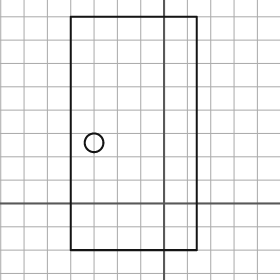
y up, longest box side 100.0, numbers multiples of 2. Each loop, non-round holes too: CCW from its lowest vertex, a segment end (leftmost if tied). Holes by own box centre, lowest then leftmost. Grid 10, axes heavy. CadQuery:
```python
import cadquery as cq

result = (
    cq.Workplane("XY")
    .moveTo(-40.0, -20.0)
    .lineTo(14.0, -20.0)
    .lineTo(14.0, 80.0)
    .lineTo(-40.0, 80.0)
    .close()
    .moveTo(-30.0, 26.0)
    .circle(4.0)
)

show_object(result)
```